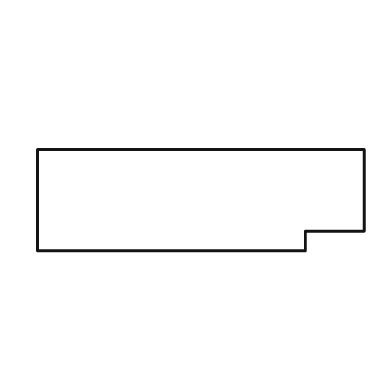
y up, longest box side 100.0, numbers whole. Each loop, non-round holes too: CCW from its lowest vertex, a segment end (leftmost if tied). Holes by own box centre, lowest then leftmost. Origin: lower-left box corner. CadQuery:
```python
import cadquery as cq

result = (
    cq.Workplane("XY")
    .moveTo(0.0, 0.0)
    .lineTo(82.0, 0.0)
    .lineTo(82.0, 6.0)
    .lineTo(100.0, 6.0)
    .lineTo(100.0, 31.0)
    .lineTo(0.0, 31.0)
    .close()
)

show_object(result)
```